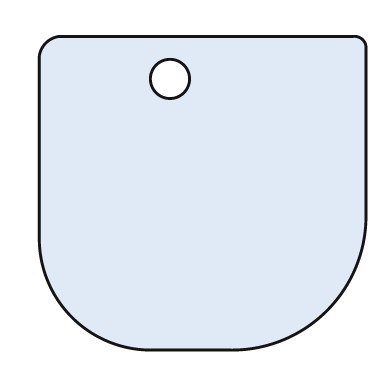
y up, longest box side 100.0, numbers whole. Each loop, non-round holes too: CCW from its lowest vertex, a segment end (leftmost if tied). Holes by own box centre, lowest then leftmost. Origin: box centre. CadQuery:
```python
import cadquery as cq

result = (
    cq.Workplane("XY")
    .moveTo(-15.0, -48.0)
    .lineTo(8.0, -48.0)
    .threePointArc((38.0, -36.0), (50.0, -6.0))
    .lineTo(50.0, 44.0)
    .threePointArc((49.0, 47.0), (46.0, 48.0))
    .lineTo(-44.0, 48.0)
    .threePointArc((-48.0, 46.0), (-50.0, 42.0))
    .lineTo(-50.0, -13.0)
    .threePointArc((-40.0, -38.0), (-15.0, -48.0))
    .close()
    .moveTo(-10.0, 35.0)
    .circle(6.0)
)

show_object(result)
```